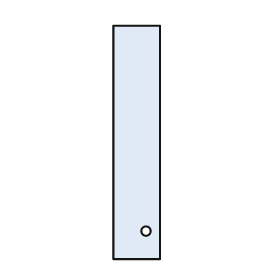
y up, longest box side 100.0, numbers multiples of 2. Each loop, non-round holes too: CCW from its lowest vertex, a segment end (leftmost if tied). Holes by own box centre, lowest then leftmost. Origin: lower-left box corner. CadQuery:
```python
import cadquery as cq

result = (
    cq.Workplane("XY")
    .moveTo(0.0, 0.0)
    .lineTo(20.0, 0.0)
    .lineTo(20.0, 100.0)
    .lineTo(0.0, 100.0)
    .close()
    .moveTo(14.0, 12.0)
    .circle(2.0)
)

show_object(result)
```